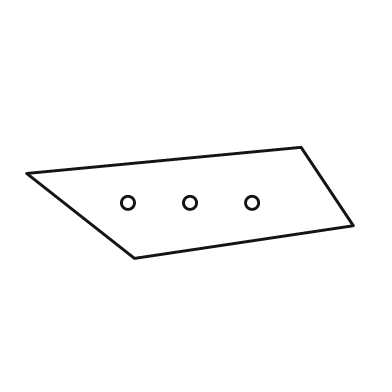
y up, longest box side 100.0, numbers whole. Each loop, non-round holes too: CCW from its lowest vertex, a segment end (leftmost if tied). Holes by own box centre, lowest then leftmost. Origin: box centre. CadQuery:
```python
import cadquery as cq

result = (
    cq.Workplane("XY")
    .moveTo(-17.0, -17.0)
    .lineTo(50.0, -7.0)
    .lineTo(34.0, 17.0)
    .lineTo(-50.0, 9.0)
    .close()
    .moveTo(-19.0, 0.0)
    .circle(2.0)
    .moveTo(0.0, 0.0)
    .circle(2.0)
    .moveTo(19.0, 0.0)
    .circle(2.0)
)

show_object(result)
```